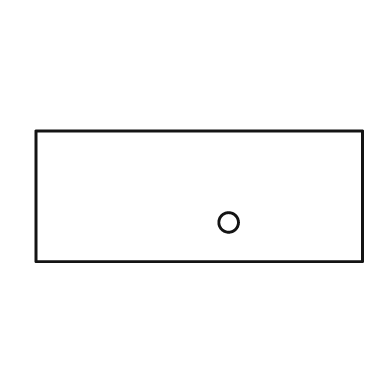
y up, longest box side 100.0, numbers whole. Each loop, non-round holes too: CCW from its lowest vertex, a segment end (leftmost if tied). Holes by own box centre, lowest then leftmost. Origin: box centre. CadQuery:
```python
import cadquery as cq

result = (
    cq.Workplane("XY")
    .moveTo(-50.0, -20.0)
    .lineTo(50.0, -20.0)
    .lineTo(50.0, 20.0)
    .lineTo(-50.0, 20.0)
    .close()
    .moveTo(9.0, -8.0)
    .circle(3.0)
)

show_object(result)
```